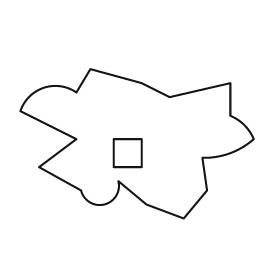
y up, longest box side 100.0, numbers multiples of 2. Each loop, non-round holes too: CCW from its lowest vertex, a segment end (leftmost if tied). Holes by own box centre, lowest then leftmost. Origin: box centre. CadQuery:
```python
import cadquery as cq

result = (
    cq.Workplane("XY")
    .moveTo(20.0, -32.0)
    .lineTo(30.0, -20.0)
    .lineTo(28.0, -6.0)
    .threePointArc((40.0, -4.0), (50.0, 2.0))
    .threePointArc((46.0, 8.0), (40.0, 12.0))
    .lineTo(40.0, 26.0)
    .lineTo(14.0, 20.0)
    .lineTo(2.0, 26.0)
    .lineTo(-20.0, 32.0)
    .lineTo(-26.0, 22.0)
    .threePointArc((-40.0, 24.0), (-50.0, 14.0))
    .lineTo(-26.0, 2.0)
    .lineTo(-42.0, -10.0)
    .lineTo(-24.0, -20.0)
    .threePointArc((-14.0, -26.0), (-8.0, -16.0))
    .lineTo(4.0, -26.0)
    .close()
    .moveTo(-10.0, -10.0)
    .lineTo(2.0, -10.0)
    .lineTo(2.0, 2.0)
    .lineTo(-10.0, 2.0)
    .close()
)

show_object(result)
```